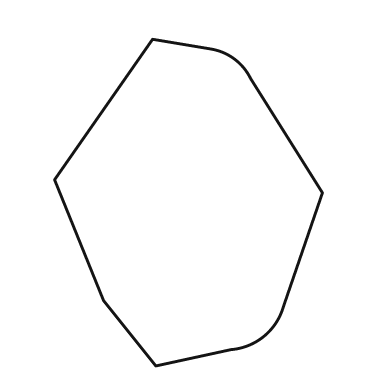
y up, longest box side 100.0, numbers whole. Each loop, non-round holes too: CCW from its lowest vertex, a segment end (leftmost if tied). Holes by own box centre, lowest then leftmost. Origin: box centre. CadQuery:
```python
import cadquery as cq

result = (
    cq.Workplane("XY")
    .moveTo(-10.0, -50.0)
    .lineTo(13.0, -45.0)
    .threePointArc((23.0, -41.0), (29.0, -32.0))
    .lineTo(41.0, 3.0)
    .lineTo(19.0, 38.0)
    .threePointArc((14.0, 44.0), (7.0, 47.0))
    .lineTo(-11.0, 50.0)
    .lineTo(-41.0, 7.0)
    .lineTo(-26.0, -30.0)
    .close()
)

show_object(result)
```